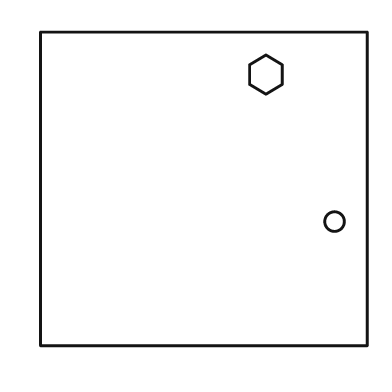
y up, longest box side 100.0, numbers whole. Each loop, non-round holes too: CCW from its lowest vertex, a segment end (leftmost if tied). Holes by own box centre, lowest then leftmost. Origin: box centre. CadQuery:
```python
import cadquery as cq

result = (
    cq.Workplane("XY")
    .moveTo(-50.0, -48.0)
    .lineTo(50.0, -48.0)
    .lineTo(50.0, 48.0)
    .lineTo(-50.0, 48.0)
    .close()
    .moveTo(40.0, -10.0)
    .circle(3.0)
    .moveTo(19.0, 29.0)
    .lineTo(24.0, 32.0)
    .lineTo(24.0, 38.0)
    .lineTo(19.0, 41.0)
    .lineTo(14.0, 38.0)
    .lineTo(14.0, 32.0)
    .close()
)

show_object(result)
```